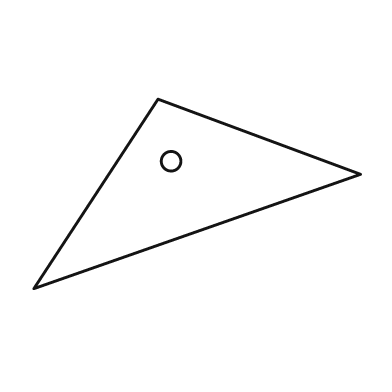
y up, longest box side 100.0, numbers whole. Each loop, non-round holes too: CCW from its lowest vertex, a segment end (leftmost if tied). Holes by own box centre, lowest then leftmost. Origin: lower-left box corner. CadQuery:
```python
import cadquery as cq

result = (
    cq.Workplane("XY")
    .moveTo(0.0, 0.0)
    .lineTo(100.0, 35.0)
    .lineTo(38.0, 58.0)
    .close()
    .moveTo(42.0, 39.0)
    .circle(3.0)
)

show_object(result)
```